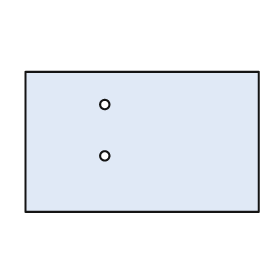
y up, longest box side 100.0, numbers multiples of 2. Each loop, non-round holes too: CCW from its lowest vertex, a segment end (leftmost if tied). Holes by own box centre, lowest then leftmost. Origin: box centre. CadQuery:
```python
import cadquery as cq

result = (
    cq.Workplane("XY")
    .moveTo(-50.0, -30.0)
    .lineTo(50.0, -30.0)
    .lineTo(50.0, 30.0)
    .lineTo(-50.0, 30.0)
    .close()
    .moveTo(-16.0, -6.0)
    .circle(2.0)
    .moveTo(-16.0, 16.0)
    .circle(2.0)
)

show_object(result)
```